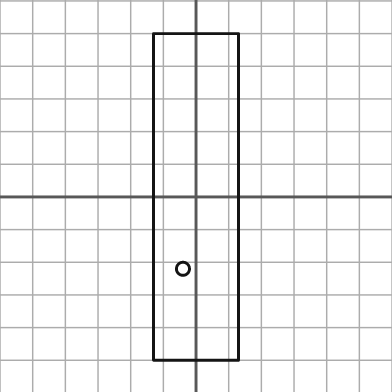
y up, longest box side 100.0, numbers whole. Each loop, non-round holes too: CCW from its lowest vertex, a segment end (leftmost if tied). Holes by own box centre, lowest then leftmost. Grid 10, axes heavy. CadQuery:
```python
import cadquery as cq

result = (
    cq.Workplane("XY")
    .moveTo(-13.0, -50.0)
    .lineTo(13.0, -50.0)
    .lineTo(13.0, 50.0)
    .lineTo(-13.0, 50.0)
    .close()
    .moveTo(-4.0, -22.0)
    .circle(2.0)
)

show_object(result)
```